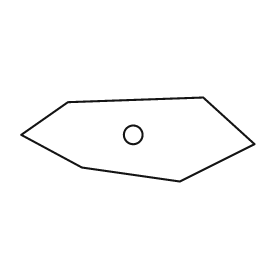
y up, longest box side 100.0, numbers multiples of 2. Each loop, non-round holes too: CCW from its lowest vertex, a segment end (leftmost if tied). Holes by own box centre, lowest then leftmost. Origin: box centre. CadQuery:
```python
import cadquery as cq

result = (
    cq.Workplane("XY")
    .moveTo(18.0, -18.0)
    .lineTo(50.0, -2.0)
    .lineTo(28.0, 18.0)
    .lineTo(-30.0, 16.0)
    .lineTo(-50.0, 2.0)
    .lineTo(-24.0, -12.0)
    .close()
    .moveTo(-2.0, 2.0)
    .circle(4.0)
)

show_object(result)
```